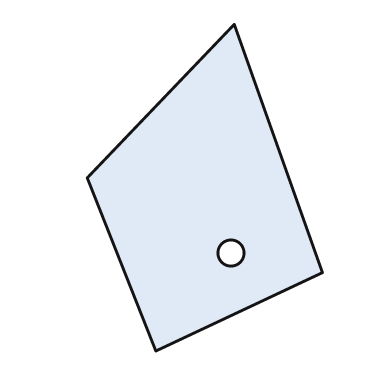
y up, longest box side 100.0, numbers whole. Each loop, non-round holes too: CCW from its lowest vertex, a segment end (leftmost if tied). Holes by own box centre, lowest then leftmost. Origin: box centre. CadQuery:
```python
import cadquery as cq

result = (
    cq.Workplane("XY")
    .moveTo(-15.0, -50.0)
    .lineTo(36.0, -26.0)
    .lineTo(9.0, 50.0)
    .lineTo(-36.0, 3.0)
    .close()
    .moveTo(8.0, -20.0)
    .circle(4.0)
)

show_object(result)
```